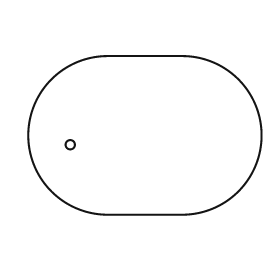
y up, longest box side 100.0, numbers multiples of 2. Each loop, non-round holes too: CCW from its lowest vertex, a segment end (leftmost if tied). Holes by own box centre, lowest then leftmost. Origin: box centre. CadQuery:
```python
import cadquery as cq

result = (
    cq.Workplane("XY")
    .moveTo(-16.0, -34.0)
    .lineTo(16.0, -34.0)
    .threePointArc((50.0, 0.0), (16.0, 34.0))
    .lineTo(-16.0, 34.0)
    .threePointArc((-50.0, 0.0), (-16.0, -34.0))
    .close()
    .moveTo(-32.0, -4.0)
    .circle(2.0)
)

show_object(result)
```